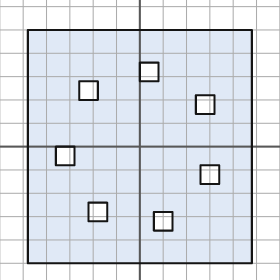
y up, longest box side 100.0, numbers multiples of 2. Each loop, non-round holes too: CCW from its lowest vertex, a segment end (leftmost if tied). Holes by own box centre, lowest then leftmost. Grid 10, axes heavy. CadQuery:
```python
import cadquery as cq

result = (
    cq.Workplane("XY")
    .moveTo(-48.0, -50.0)
    .lineTo(48.0, -50.0)
    .lineTo(48.0, 50.0)
    .lineTo(-48.0, 50.0)
    .close()
    .moveTo(6.0, -36.0)
    .lineTo(14.0, -36.0)
    .lineTo(14.0, -28.0)
    .lineTo(6.0, -28.0)
    .close()
    .moveTo(-22.0, -32.0)
    .lineTo(-14.0, -32.0)
    .lineTo(-14.0, -24.0)
    .lineTo(-22.0, -24.0)
    .close()
    .moveTo(26.0, -16.0)
    .lineTo(34.0, -16.0)
    .lineTo(34.0, -8.0)
    .lineTo(26.0, -8.0)
    .close()
    .moveTo(-36.0, -8.0)
    .lineTo(-28.0, -8.0)
    .lineTo(-28.0, 0.0)
    .lineTo(-36.0, 0.0)
    .close()
    .moveTo(24.0, 14.0)
    .lineTo(32.0, 14.0)
    .lineTo(32.0, 22.0)
    .lineTo(24.0, 22.0)
    .close()
    .moveTo(-26.0, 20.0)
    .lineTo(-18.0, 20.0)
    .lineTo(-18.0, 28.0)
    .lineTo(-26.0, 28.0)
    .close()
    .moveTo(0.0, 28.0)
    .lineTo(8.0, 28.0)
    .lineTo(8.0, 36.0)
    .lineTo(0.0, 36.0)
    .close()
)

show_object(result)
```